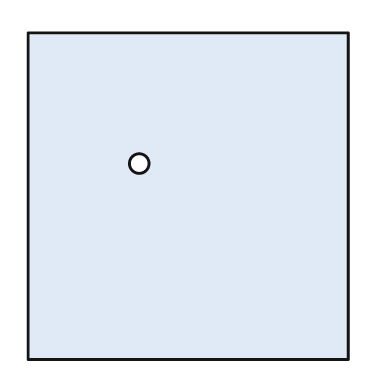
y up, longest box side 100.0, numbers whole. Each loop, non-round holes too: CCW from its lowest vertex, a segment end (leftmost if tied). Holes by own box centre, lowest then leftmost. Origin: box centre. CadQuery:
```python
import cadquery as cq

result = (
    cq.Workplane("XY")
    .moveTo(-49.0, -50.0)
    .lineTo(49.0, -50.0)
    .lineTo(49.0, 50.0)
    .lineTo(-49.0, 50.0)
    .close()
    .moveTo(-15.0, 10.0)
    .circle(3.0)
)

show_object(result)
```